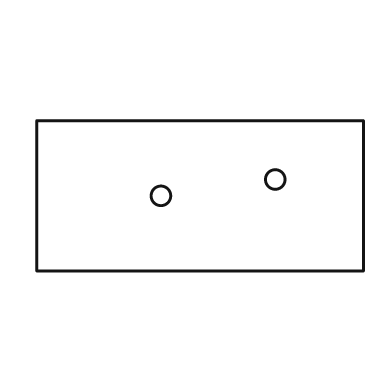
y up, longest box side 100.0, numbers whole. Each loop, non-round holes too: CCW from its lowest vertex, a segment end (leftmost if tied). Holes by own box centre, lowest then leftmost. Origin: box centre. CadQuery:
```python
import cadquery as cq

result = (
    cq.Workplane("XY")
    .moveTo(-50.0, -23.0)
    .lineTo(50.0, -23.0)
    .lineTo(50.0, 23.0)
    .lineTo(-50.0, 23.0)
    .close()
    .moveTo(-12.0, 0.0)
    .circle(3.0)
    .moveTo(23.0, 5.0)
    .circle(3.0)
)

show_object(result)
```